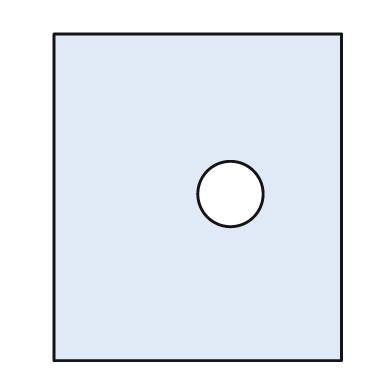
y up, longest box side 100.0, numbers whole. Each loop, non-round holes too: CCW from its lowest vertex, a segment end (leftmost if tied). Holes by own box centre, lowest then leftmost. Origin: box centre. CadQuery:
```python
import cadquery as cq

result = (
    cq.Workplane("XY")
    .moveTo(-44.0, -50.0)
    .lineTo(44.0, -50.0)
    .lineTo(44.0, 50.0)
    .lineTo(-44.0, 50.0)
    .close()
    .moveTo(10.0, 1.0)
    .circle(10.0)
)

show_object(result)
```